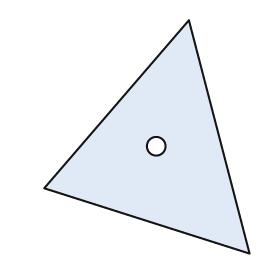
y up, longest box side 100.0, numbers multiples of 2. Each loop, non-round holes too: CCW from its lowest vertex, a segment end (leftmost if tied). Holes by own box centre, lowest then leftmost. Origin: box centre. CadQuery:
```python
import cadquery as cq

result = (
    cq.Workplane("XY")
    .moveTo(44.0, -50.0)
    .lineTo(18.0, 50.0)
    .lineTo(-44.0, -22.0)
    .close()
    .moveTo(4.0, -4.0)
    .circle(4.0)
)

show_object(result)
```